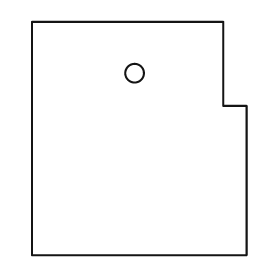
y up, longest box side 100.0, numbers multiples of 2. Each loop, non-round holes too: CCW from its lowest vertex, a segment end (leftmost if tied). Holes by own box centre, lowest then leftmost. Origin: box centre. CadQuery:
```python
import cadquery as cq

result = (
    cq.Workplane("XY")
    .moveTo(-46.0, -50.0)
    .lineTo(46.0, -50.0)
    .lineTo(46.0, 14.0)
    .lineTo(36.0, 14.0)
    .lineTo(36.0, 50.0)
    .lineTo(-46.0, 50.0)
    .close()
    .moveTo(-2.0, 28.0)
    .circle(4.0)
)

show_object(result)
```